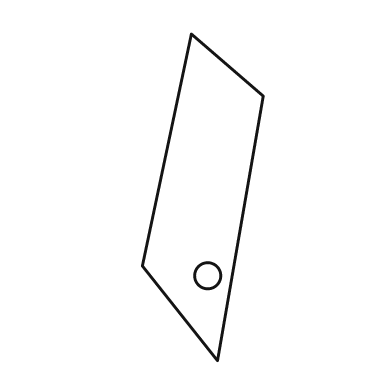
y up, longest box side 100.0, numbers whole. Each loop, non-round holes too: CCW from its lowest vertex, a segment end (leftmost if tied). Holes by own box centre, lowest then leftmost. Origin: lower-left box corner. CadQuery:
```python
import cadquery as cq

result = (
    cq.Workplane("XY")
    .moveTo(23.0, 0.0)
    .lineTo(37.0, 81.0)
    .lineTo(15.0, 100.0)
    .lineTo(0.0, 29.0)
    .close()
    .moveTo(20.0, 26.0)
    .circle(4.0)
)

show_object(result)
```